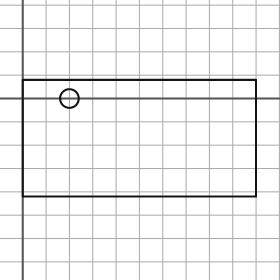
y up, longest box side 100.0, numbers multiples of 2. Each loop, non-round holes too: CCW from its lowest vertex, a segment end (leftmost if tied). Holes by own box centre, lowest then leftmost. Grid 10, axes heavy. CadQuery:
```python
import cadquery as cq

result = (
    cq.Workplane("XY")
    .moveTo(0.0, -42.0)
    .lineTo(100.0, -42.0)
    .lineTo(100.0, 8.0)
    .lineTo(0.0, 8.0)
    .close()
    .moveTo(20.0, 0.0)
    .circle(4.0)
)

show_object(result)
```